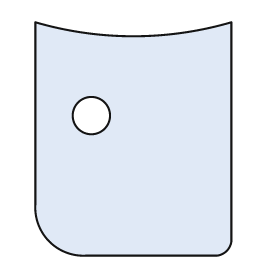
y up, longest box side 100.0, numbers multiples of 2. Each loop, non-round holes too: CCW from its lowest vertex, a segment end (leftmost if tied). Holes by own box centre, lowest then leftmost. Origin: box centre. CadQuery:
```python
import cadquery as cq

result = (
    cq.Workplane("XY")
    .moveTo(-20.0, -50.0)
    .lineTo(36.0, -50.0)
    .threePointArc((40.0, -48.0), (42.0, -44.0))
    .lineTo(42.0, 50.0)
    .threePointArc((0.0, 44.0), (-42.0, 50.0))
    .lineTo(-42.0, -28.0)
    .threePointArc((-36.0, -44.0), (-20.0, -50.0))
    .close()
    .moveTo(-18.0, 10.0)
    .circle(8.0)
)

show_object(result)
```